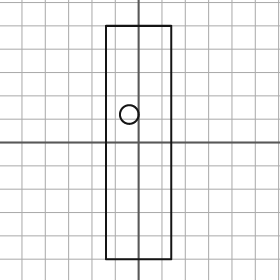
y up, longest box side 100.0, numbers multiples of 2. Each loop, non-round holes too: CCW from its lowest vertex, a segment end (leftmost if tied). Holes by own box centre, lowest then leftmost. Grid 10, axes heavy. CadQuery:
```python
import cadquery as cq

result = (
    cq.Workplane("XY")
    .moveTo(-14.0, -50.0)
    .lineTo(14.0, -50.0)
    .lineTo(14.0, 50.0)
    .lineTo(-14.0, 50.0)
    .close()
    .moveTo(-4.0, 12.0)
    .circle(4.0)
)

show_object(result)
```